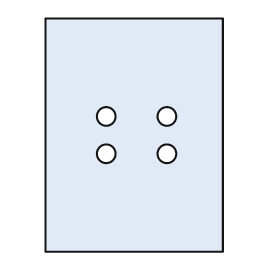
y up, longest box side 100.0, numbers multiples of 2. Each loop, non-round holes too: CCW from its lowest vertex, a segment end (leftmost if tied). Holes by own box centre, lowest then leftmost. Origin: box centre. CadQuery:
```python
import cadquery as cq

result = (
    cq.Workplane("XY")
    .moveTo(-38.0, -50.0)
    .lineTo(38.0, -50.0)
    .lineTo(38.0, 50.0)
    .lineTo(-38.0, 50.0)
    .close()
    .moveTo(-12.0, -8.0)
    .circle(4.0)
    .moveTo(14.0, -8.0)
    .circle(4.0)
    .moveTo(-12.0, 8.0)
    .circle(4.0)
    .moveTo(14.0, 8.0)
    .circle(4.0)
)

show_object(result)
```